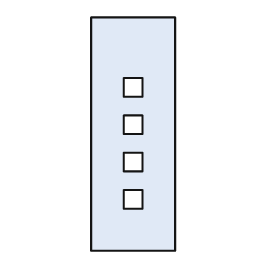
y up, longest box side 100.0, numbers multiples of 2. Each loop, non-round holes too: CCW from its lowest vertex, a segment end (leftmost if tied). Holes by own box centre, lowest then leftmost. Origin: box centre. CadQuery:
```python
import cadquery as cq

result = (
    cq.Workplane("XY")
    .moveTo(-18.0, -50.0)
    .lineTo(18.0, -50.0)
    .lineTo(18.0, 50.0)
    .lineTo(-18.0, 50.0)
    .close()
    .moveTo(-4.0, -32.0)
    .lineTo(4.0, -32.0)
    .lineTo(4.0, -24.0)
    .lineTo(-4.0, -24.0)
    .close()
    .moveTo(-4.0, -16.0)
    .lineTo(4.0, -16.0)
    .lineTo(4.0, -8.0)
    .lineTo(-4.0, -8.0)
    .close()
    .moveTo(-4.0, 0.0)
    .lineTo(4.0, 0.0)
    .lineTo(4.0, 8.0)
    .lineTo(-4.0, 8.0)
    .close()
    .moveTo(-4.0, 16.0)
    .lineTo(4.0, 16.0)
    .lineTo(4.0, 24.0)
    .lineTo(-4.0, 24.0)
    .close()
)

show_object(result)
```